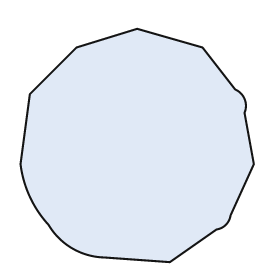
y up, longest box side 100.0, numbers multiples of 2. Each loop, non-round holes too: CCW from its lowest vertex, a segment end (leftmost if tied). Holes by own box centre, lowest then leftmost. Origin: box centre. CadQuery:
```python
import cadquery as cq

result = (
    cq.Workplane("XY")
    .moveTo(14.0, -50.0)
    .lineTo(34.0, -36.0)
    .threePointArc((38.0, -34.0), (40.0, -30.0))
    .lineTo(50.0, -8.0)
    .lineTo(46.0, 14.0)
    .threePointArc((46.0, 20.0), (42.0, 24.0))
    .lineTo(28.0, 42.0)
    .lineTo(0.0, 50.0)
    .lineTo(-26.0, 42.0)
    .lineTo(-46.0, 22.0)
    .lineTo(-50.0, -8.0)
    .threePointArc((-46.0, -22.0), (-38.0, -34.0))
    .threePointArc((-28.0, -44.0), (-14.0, -48.0))
    .close()
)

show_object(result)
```